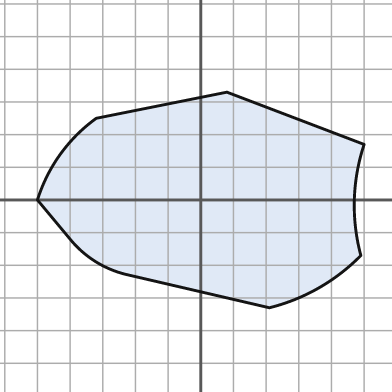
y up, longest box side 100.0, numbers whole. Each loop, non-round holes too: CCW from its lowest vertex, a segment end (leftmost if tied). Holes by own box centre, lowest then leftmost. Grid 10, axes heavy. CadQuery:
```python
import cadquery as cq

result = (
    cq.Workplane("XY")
    .moveTo(21.0, -33.0)
    .threePointArc((36.0, -27.0), (49.0, -17.0))
    .threePointArc((47.0, 0.0), (50.0, 17.0))
    .lineTo(8.0, 33.0)
    .lineTo(-32.0, 25.0)
    .threePointArc((-43.0, 14.0), (-50.0, 0.0))
    .lineTo(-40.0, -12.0)
    .threePointArc((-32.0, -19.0), (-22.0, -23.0))
    .close()
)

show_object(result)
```